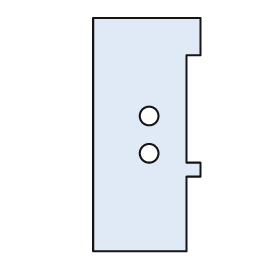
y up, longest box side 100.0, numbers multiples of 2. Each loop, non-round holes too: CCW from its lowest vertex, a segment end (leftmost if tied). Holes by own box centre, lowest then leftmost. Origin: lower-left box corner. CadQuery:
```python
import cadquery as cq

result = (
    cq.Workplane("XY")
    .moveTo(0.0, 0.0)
    .lineTo(40.0, 0.0)
    .lineTo(40.0, 32.0)
    .lineTo(46.0, 32.0)
    .lineTo(46.0, 38.0)
    .lineTo(40.0, 38.0)
    .lineTo(40.0, 84.0)
    .lineTo(46.0, 84.0)
    .lineTo(46.0, 100.0)
    .lineTo(0.0, 100.0)
    .close()
    .moveTo(24.0, 42.0)
    .circle(4.0)
    .moveTo(24.0, 58.0)
    .circle(4.0)
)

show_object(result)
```